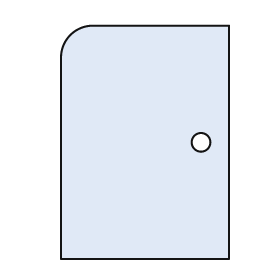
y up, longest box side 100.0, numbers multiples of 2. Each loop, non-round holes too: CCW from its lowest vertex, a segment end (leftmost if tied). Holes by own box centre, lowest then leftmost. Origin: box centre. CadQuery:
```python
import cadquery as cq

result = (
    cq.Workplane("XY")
    .moveTo(-36.0, -50.0)
    .lineTo(36.0, -50.0)
    .lineTo(36.0, 50.0)
    .lineTo(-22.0, 50.0)
    .threePointArc((-32.0, 46.0), (-36.0, 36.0))
    .close()
    .moveTo(24.0, 0.0)
    .circle(4.0)
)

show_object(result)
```